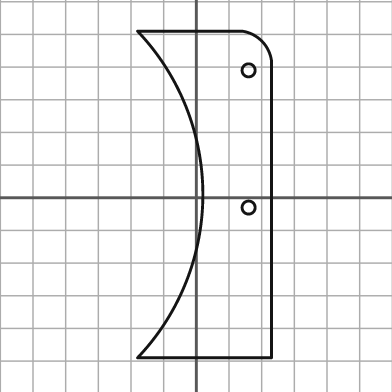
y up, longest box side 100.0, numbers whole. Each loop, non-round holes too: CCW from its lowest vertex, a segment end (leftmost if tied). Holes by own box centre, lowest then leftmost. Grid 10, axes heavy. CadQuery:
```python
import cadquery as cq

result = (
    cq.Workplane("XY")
    .moveTo(-18.0, -49.0)
    .lineTo(23.0, -49.0)
    .lineTo(23.0, 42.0)
    .threePointArc((20.0, 48.0), (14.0, 51.0))
    .lineTo(-18.0, 51.0)
    .threePointArc((2.0, 1.0), (-18.0, -49.0))
    .close()
    .moveTo(16.0, -3.0)
    .circle(2.0)
    .moveTo(16.0, 39.0)
    .circle(2.0)
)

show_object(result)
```